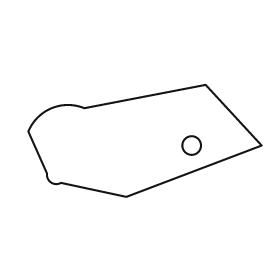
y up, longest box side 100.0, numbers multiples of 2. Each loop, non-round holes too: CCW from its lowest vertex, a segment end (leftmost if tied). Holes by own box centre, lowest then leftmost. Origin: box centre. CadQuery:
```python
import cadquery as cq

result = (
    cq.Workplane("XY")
    .moveTo(-8.0, -24.0)
    .lineTo(50.0, -2.0)
    .lineTo(26.0, 24.0)
    .lineTo(-26.0, 14.0)
    .threePointArc((-40.0, 14.0), (-50.0, 4.0))
    .lineTo(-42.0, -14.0)
    .threePointArc((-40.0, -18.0), (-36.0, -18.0))
    .close()
    .moveTo(20.0, -2.0)
    .circle(4.0)
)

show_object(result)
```